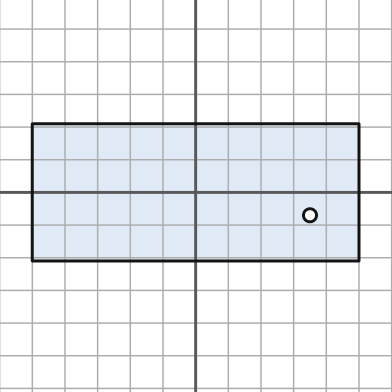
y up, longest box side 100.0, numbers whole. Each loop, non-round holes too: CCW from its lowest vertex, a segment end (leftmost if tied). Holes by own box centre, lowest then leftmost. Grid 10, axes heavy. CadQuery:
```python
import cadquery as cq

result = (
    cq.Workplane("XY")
    .moveTo(-50.0, -21.0)
    .lineTo(50.0, -21.0)
    .lineTo(50.0, 21.0)
    .lineTo(-50.0, 21.0)
    .close()
    .moveTo(35.0, -7.0)
    .circle(2.0)
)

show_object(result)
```